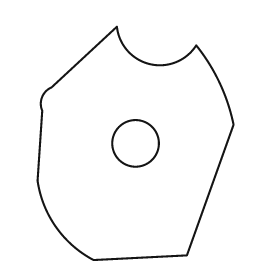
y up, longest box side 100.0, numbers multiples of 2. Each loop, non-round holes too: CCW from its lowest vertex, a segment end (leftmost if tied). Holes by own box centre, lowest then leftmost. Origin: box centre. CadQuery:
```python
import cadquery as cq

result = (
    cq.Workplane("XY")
    .moveTo(-18.0, -50.0)
    .lineTo(22.0, -48.0)
    .lineTo(42.0, 8.0)
    .threePointArc((36.0, 26.0), (26.0, 42.0))
    .threePointArc((6.0, 34.0), (-8.0, 50.0))
    .lineTo(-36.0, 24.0)
    .threePointArc((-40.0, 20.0), (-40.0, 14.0))
    .lineTo(-42.0, -16.0)
    .threePointArc((-34.0, -36.0), (-18.0, -50.0))
    .close()
    .moveTo(0.0, 0.0)
    .circle(10.0)
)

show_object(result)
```